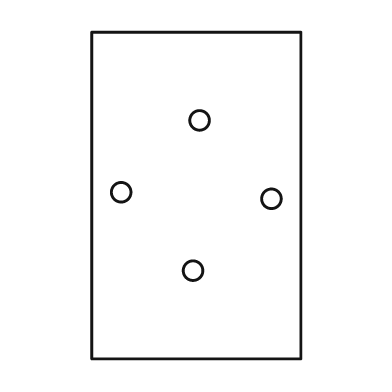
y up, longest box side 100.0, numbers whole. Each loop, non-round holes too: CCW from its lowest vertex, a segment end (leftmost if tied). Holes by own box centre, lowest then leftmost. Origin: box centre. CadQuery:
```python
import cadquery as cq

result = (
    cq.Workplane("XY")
    .moveTo(-32.0, -50.0)
    .lineTo(32.0, -50.0)
    .lineTo(32.0, 50.0)
    .lineTo(-32.0, 50.0)
    .close()
    .moveTo(-1.0, -23.0)
    .circle(3.0)
    .moveTo(23.0, -1.0)
    .circle(3.0)
    .moveTo(-23.0, 1.0)
    .circle(3.0)
    .moveTo(1.0, 23.0)
    .circle(3.0)
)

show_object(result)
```